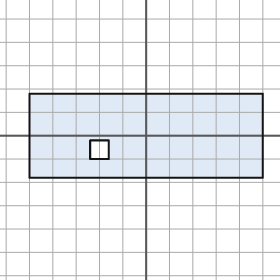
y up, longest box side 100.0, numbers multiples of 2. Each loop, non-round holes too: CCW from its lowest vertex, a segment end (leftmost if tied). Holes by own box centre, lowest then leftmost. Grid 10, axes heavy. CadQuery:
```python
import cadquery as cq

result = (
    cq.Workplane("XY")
    .moveTo(-50.0, -18.0)
    .lineTo(50.0, -18.0)
    .lineTo(50.0, 18.0)
    .lineTo(-50.0, 18.0)
    .close()
    .moveTo(-24.0, -10.0)
    .lineTo(-16.0, -10.0)
    .lineTo(-16.0, -2.0)
    .lineTo(-24.0, -2.0)
    .close()
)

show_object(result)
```